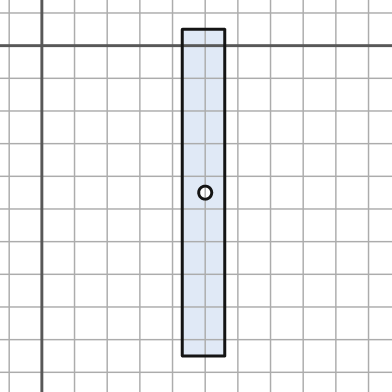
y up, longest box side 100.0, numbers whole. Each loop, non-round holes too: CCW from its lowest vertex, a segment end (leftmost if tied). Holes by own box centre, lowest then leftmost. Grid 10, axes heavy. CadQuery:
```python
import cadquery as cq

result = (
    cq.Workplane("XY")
    .moveTo(43.0, -95.0)
    .lineTo(56.0, -95.0)
    .lineTo(56.0, 5.0)
    .lineTo(43.0, 5.0)
    .close()
    .moveTo(50.0, -45.0)
    .circle(2.0)
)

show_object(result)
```